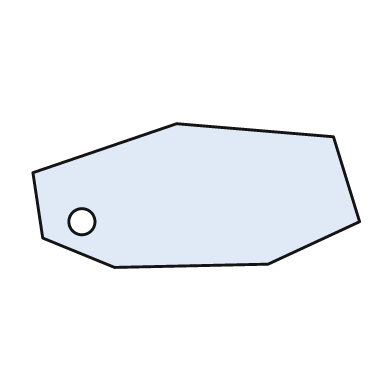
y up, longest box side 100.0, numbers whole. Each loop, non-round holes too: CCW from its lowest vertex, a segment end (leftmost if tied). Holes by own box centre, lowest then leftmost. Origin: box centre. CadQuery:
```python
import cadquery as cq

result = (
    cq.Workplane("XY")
    .moveTo(-25.0, -22.0)
    .lineTo(22.0, -21.0)
    .lineTo(50.0, -8.0)
    .lineTo(42.0, 18.0)
    .lineTo(-6.0, 22.0)
    .lineTo(-50.0, 7.0)
    .lineTo(-47.0, -13.0)
    .close()
    .moveTo(-35.0, -8.0)
    .circle(4.0)
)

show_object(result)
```